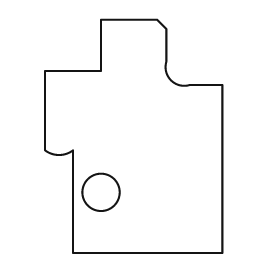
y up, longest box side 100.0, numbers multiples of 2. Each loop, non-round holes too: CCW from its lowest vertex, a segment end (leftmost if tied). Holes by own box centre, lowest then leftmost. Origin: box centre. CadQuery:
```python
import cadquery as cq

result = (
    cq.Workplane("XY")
    .moveTo(-26.0, -50.0)
    .lineTo(38.0, -50.0)
    .lineTo(38.0, 22.0)
    .lineTo(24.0, 22.0)
    .threePointArc((16.0, 24.0), (14.0, 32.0))
    .lineTo(14.0, 46.0)
    .lineTo(10.0, 50.0)
    .lineTo(-14.0, 50.0)
    .lineTo(-14.0, 28.0)
    .lineTo(-38.0, 28.0)
    .lineTo(-38.0, -6.0)
    .threePointArc((-32.0, -8.0), (-26.0, -6.0))
    .close()
    .moveTo(-14.0, -24.0)
    .circle(8.0)
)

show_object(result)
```